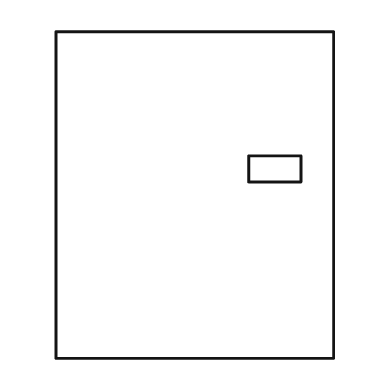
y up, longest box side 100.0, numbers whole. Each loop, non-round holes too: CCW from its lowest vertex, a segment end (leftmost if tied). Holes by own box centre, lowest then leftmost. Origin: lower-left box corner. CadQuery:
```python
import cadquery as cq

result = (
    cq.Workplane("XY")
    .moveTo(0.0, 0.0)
    .lineTo(85.0, 0.0)
    .lineTo(85.0, 100.0)
    .lineTo(0.0, 100.0)
    .close()
    .moveTo(59.0, 54.0)
    .lineTo(75.0, 54.0)
    .lineTo(75.0, 62.0)
    .lineTo(59.0, 62.0)
    .close()
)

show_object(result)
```